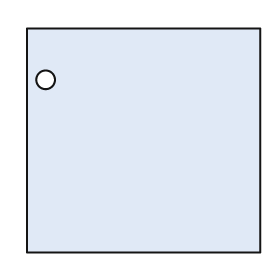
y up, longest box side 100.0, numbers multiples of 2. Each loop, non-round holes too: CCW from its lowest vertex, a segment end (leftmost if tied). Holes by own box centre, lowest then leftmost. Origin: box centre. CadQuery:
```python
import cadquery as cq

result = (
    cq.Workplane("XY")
    .moveTo(-50.0, -48.0)
    .lineTo(50.0, -48.0)
    .lineTo(50.0, 48.0)
    .lineTo(-50.0, 48.0)
    .close()
    .moveTo(-42.0, 26.0)
    .circle(4.0)
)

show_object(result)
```